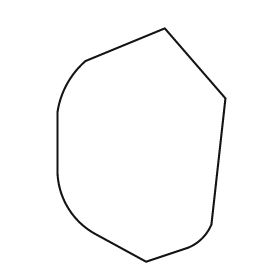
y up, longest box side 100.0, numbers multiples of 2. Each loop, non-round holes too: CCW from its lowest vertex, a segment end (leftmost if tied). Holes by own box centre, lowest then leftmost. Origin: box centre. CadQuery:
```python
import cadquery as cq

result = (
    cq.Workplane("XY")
    .moveTo(2.0, -50.0)
    .lineTo(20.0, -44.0)
    .threePointArc((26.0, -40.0), (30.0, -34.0))
    .lineTo(36.0, 20.0)
    .lineTo(10.0, 50.0)
    .lineTo(-24.0, 36.0)
    .threePointArc((-32.0, 26.0), (-36.0, 14.0))
    .lineTo(-36.0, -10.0)
    .threePointArc((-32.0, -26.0), (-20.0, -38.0))
    .close()
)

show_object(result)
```